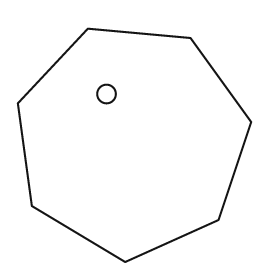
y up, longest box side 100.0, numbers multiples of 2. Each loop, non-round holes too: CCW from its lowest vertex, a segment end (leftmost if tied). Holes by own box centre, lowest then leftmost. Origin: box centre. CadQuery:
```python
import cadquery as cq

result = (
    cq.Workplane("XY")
    .moveTo(-4.0, -50.0)
    .lineTo(36.0, -32.0)
    .lineTo(50.0, 10.0)
    .lineTo(24.0, 46.0)
    .lineTo(-20.0, 50.0)
    .lineTo(-50.0, 18.0)
    .lineTo(-44.0, -26.0)
    .close()
    .moveTo(-12.0, 22.0)
    .circle(4.0)
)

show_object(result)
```